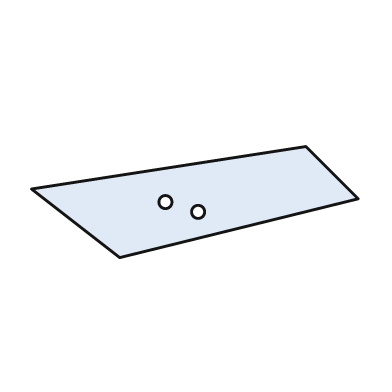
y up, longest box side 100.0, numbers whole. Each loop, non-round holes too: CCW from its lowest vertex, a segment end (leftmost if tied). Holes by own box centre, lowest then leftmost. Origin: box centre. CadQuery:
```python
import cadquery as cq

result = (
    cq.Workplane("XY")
    .moveTo(-23.0, -17.0)
    .lineTo(50.0, 1.0)
    .lineTo(34.0, 17.0)
    .lineTo(-50.0, 4.0)
    .close()
    .moveTo(1.0, -3.0)
    .circle(2.0)
    .moveTo(-9.0, 0.0)
    .circle(2.0)
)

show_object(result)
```